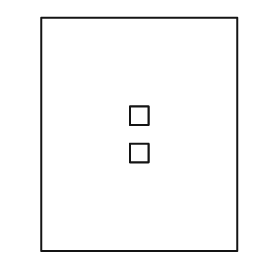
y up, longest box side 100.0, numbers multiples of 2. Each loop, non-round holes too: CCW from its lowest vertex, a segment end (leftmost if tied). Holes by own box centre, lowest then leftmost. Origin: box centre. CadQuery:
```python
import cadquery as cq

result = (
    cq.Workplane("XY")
    .moveTo(-42.0, -50.0)
    .lineTo(42.0, -50.0)
    .lineTo(42.0, 50.0)
    .lineTo(-42.0, 50.0)
    .close()
    .moveTo(-4.0, -12.0)
    .lineTo(4.0, -12.0)
    .lineTo(4.0, -4.0)
    .lineTo(-4.0, -4.0)
    .close()
    .moveTo(-4.0, 4.0)
    .lineTo(4.0, 4.0)
    .lineTo(4.0, 12.0)
    .lineTo(-4.0, 12.0)
    .close()
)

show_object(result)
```